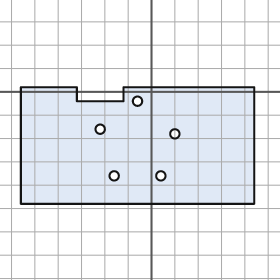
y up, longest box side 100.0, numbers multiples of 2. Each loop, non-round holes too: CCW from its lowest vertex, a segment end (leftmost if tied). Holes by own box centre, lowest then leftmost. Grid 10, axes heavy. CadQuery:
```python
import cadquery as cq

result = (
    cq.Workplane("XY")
    .moveTo(-56.0, -48.0)
    .lineTo(44.0, -48.0)
    .lineTo(44.0, 2.0)
    .lineTo(-12.0, 2.0)
    .lineTo(-12.0, -4.0)
    .lineTo(-32.0, -4.0)
    .lineTo(-32.0, 2.0)
    .lineTo(-56.0, 2.0)
    .close()
    .moveTo(-16.0, -36.0)
    .circle(2.0)
    .moveTo(4.0, -36.0)
    .circle(2.0)
    .moveTo(10.0, -18.0)
    .circle(2.0)
    .moveTo(-22.0, -16.0)
    .circle(2.0)
    .moveTo(-6.0, -4.0)
    .circle(2.0)
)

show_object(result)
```